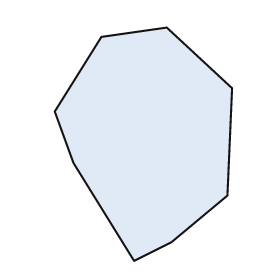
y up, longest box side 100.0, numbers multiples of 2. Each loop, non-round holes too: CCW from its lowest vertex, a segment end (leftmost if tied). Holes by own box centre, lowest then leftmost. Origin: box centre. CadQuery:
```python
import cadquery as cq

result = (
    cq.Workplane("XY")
    .moveTo(-4.0, -50.0)
    .lineTo(12.0, -42.0)
    .lineTo(36.0, -22.0)
    .lineTo(38.0, 24.0)
    .lineTo(10.0, 50.0)
    .lineTo(-18.0, 46.0)
    .lineTo(-38.0, 14.0)
    .lineTo(-30.0, -8.0)
    .close()
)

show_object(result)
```